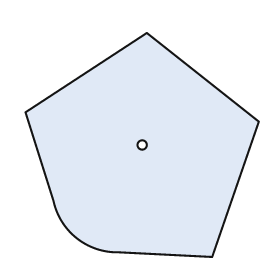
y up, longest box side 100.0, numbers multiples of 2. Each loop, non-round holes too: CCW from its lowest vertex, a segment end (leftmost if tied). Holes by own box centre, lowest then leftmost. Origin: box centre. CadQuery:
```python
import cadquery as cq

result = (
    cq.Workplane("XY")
    .moveTo(30.0, -48.0)
    .lineTo(50.0, 10.0)
    .lineTo(2.0, 48.0)
    .lineTo(-50.0, 14.0)
    .lineTo(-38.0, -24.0)
    .threePointArc((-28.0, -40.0), (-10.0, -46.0))
    .close()
    .moveTo(0.0, 0.0)
    .circle(2.0)
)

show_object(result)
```